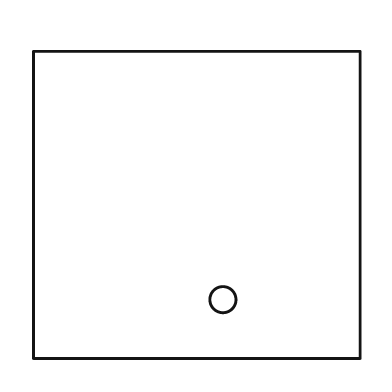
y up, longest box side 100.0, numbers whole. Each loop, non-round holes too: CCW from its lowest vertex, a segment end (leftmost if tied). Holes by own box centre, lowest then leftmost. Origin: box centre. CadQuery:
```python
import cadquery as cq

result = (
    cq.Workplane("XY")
    .moveTo(-50.0, -47.0)
    .lineTo(50.0, -47.0)
    .lineTo(50.0, 47.0)
    .lineTo(-50.0, 47.0)
    .close()
    .moveTo(8.0, -29.0)
    .circle(4.0)
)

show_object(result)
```